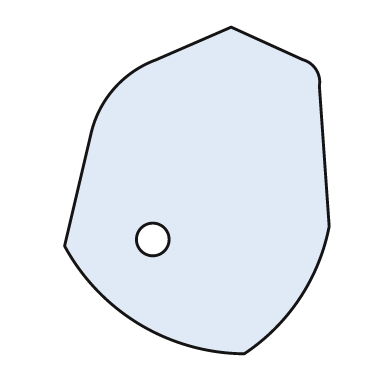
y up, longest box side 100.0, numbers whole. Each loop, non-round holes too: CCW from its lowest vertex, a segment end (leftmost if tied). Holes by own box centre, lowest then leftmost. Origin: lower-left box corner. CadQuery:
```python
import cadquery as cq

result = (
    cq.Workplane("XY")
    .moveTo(55.0, 0.0)
    .threePointArc((72.0, 17.0), (81.0, 39.0))
    .lineTo(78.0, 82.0)
    .threePointArc((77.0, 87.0), (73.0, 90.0))
    .lineTo(51.0, 100.0)
    .lineTo(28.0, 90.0)
    .threePointArc((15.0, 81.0), (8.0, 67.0))
    .lineTo(0.0, 33.0)
    .threePointArc((23.0, 9.0), (55.0, 0.0))
    .close()
    .moveTo(27.0, 35.0)
    .circle(5.0)
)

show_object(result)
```